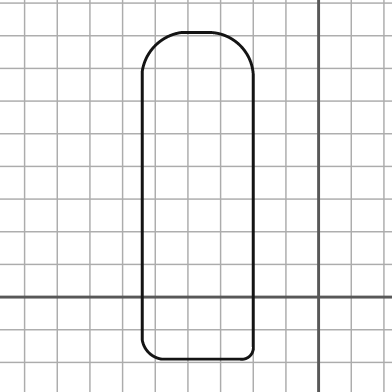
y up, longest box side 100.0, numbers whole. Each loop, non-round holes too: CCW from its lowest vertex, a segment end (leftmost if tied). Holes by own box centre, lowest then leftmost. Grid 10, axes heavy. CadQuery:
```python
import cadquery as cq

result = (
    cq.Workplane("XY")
    .moveTo(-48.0, -19.0)
    .lineTo(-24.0, -19.0)
    .threePointArc((-21.0, -18.0), (-20.0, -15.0))
    .lineTo(-20.0, 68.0)
    .threePointArc((-24.0, 77.0), (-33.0, 81.0))
    .lineTo(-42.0, 81.0)
    .threePointArc((-50.0, 77.0), (-54.0, 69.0))
    .lineTo(-54.0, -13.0)
    .threePointArc((-52.0, -17.0), (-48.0, -19.0))
    .close()
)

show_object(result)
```